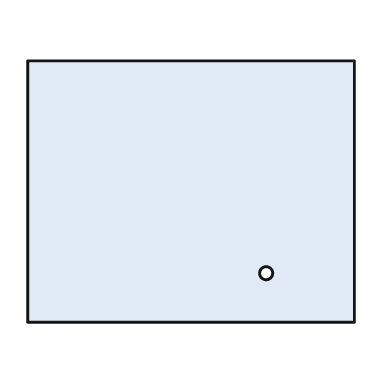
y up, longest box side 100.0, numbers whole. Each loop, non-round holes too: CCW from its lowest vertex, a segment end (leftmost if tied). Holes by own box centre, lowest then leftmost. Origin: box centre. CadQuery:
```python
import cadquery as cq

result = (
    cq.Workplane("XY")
    .moveTo(-50.0, -40.0)
    .lineTo(50.0, -40.0)
    .lineTo(50.0, 40.0)
    .lineTo(-50.0, 40.0)
    .close()
    .moveTo(23.0, -25.0)
    .circle(2.0)
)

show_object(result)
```